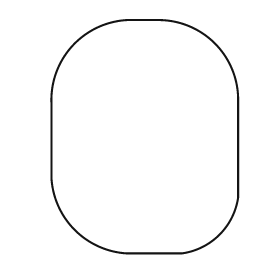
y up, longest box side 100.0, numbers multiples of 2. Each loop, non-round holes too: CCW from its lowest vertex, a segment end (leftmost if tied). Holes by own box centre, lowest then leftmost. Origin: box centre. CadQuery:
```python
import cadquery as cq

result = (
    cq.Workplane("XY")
    .moveTo(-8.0, -50.0)
    .lineTo(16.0, -50.0)
    .threePointArc((32.0, -42.0), (40.0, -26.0))
    .lineTo(40.0, 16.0)
    .threePointArc((30.0, 40.0), (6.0, 50.0))
    .lineTo(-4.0, 50.0)
    .threePointArc((-30.0, 40.0), (-40.0, 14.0))
    .lineTo(-40.0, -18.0)
    .threePointArc((-30.0, -40.0), (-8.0, -50.0))
    .close()
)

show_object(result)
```